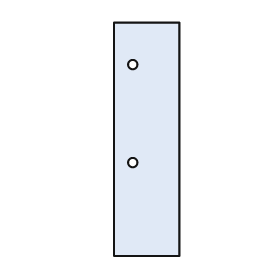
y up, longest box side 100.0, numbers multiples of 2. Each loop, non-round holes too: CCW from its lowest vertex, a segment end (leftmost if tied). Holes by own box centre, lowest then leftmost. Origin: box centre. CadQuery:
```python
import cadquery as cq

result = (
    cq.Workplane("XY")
    .moveTo(-14.0, -50.0)
    .lineTo(14.0, -50.0)
    .lineTo(14.0, 50.0)
    .lineTo(-14.0, 50.0)
    .close()
    .moveTo(-6.0, -10.0)
    .circle(2.0)
    .moveTo(-6.0, 32.0)
    .circle(2.0)
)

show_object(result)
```